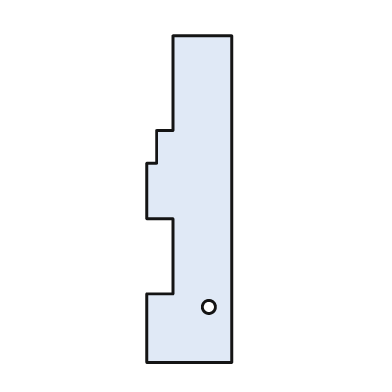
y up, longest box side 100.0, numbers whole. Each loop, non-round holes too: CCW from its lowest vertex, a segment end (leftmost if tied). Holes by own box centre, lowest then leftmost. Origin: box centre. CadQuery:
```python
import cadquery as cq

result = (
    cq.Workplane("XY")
    .moveTo(-13.0, -50.0)
    .lineTo(13.0, -50.0)
    .lineTo(13.0, 50.0)
    .lineTo(-5.0, 50.0)
    .lineTo(-5.0, 21.0)
    .lineTo(-10.0, 21.0)
    .lineTo(-10.0, 11.0)
    .lineTo(-13.0, 11.0)
    .lineTo(-13.0, -6.0)
    .lineTo(-5.0, -6.0)
    .lineTo(-5.0, -29.0)
    .lineTo(-13.0, -29.0)
    .close()
    .moveTo(6.0, -33.0)
    .circle(2.0)
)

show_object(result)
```